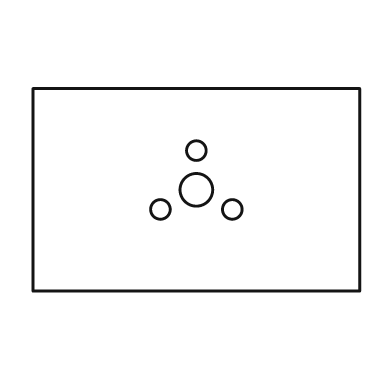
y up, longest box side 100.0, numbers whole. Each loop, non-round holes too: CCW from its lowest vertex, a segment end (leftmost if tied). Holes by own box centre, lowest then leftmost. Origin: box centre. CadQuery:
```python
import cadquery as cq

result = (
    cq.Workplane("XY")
    .moveTo(-50.0, -31.0)
    .lineTo(50.0, -31.0)
    .lineTo(50.0, 31.0)
    .lineTo(-50.0, 31.0)
    .close()
    .moveTo(-11.0, -6.0)
    .circle(3.0)
    .moveTo(11.0, -6.0)
    .circle(3.0)
    .moveTo(0.0, 0.0)
    .circle(5.0)
    .moveTo(0.0, 12.0)
    .circle(3.0)
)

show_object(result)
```